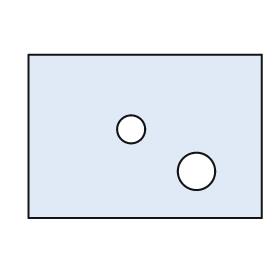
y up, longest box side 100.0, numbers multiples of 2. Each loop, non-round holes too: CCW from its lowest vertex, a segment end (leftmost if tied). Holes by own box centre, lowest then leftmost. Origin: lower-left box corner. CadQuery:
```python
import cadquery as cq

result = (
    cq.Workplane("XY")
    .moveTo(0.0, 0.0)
    .lineTo(100.0, 0.0)
    .lineTo(100.0, 70.0)
    .lineTo(0.0, 70.0)
    .close()
    .moveTo(72.0, 20.0)
    .circle(8.0)
    .moveTo(44.0, 38.0)
    .circle(6.0)
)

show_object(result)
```